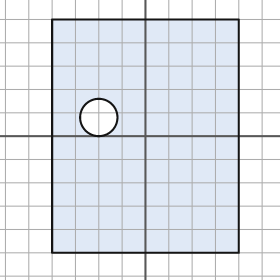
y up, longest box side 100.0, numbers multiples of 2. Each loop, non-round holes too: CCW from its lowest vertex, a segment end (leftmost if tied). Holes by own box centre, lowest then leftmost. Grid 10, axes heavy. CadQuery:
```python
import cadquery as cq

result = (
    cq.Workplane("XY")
    .moveTo(-40.0, -50.0)
    .lineTo(40.0, -50.0)
    .lineTo(40.0, 50.0)
    .lineTo(-40.0, 50.0)
    .close()
    .moveTo(-20.0, 8.0)
    .circle(8.0)
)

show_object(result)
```